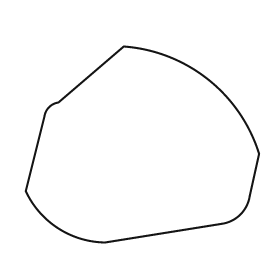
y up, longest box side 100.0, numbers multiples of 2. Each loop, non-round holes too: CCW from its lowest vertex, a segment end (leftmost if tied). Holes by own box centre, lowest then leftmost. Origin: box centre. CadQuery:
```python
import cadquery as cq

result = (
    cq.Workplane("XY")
    .moveTo(-16.0, -42.0)
    .lineTo(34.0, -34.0)
    .threePointArc((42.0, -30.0), (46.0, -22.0))
    .lineTo(50.0, -4.0)
    .threePointArc((28.0, 28.0), (-8.0, 42.0))
    .lineTo(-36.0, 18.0)
    .threePointArc((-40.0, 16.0), (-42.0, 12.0))
    .lineTo(-50.0, -20.0)
    .threePointArc((-36.0, -36.0), (-16.0, -42.0))
    .close()
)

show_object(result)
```